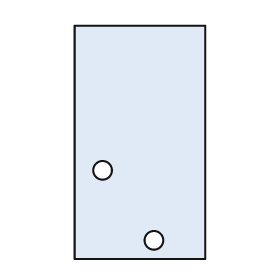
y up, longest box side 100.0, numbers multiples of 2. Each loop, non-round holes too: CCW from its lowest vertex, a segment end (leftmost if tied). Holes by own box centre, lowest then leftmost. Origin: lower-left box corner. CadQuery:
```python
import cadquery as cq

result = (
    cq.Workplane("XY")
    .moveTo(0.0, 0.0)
    .lineTo(56.0, 0.0)
    .lineTo(56.0, 100.0)
    .lineTo(0.0, 100.0)
    .close()
    .moveTo(34.0, 8.0)
    .circle(4.0)
    .moveTo(12.0, 38.0)
    .circle(4.0)
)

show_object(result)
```